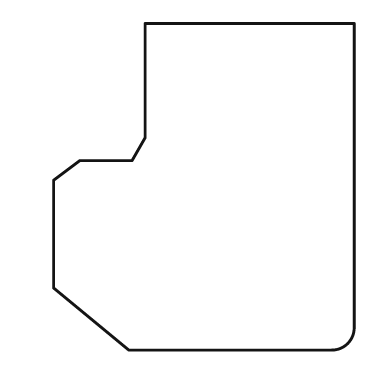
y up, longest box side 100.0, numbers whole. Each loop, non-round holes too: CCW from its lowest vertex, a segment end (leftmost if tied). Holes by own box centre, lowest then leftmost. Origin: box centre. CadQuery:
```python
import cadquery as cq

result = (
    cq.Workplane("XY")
    .moveTo(-23.0, -50.0)
    .lineTo(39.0, -50.0)
    .threePointArc((44.0, -48.0), (46.0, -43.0))
    .lineTo(46.0, 50.0)
    .lineTo(-18.0, 50.0)
    .lineTo(-18.0, 15.0)
    .lineTo(-22.0, 8.0)
    .lineTo(-38.0, 8.0)
    .lineTo(-46.0, 2.0)
    .lineTo(-46.0, -31.0)
    .close()
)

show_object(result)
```